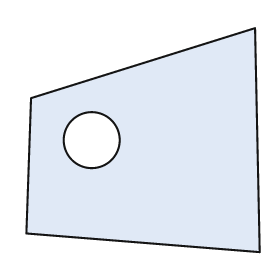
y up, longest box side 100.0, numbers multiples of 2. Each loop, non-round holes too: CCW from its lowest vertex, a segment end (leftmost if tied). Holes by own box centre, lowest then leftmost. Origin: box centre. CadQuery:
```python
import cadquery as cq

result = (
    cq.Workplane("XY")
    .moveTo(50.0, -48.0)
    .lineTo(48.0, 48.0)
    .lineTo(-48.0, 18.0)
    .lineTo(-50.0, -40.0)
    .close()
    .moveTo(-22.0, 0.0)
    .circle(12.0)
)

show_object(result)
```